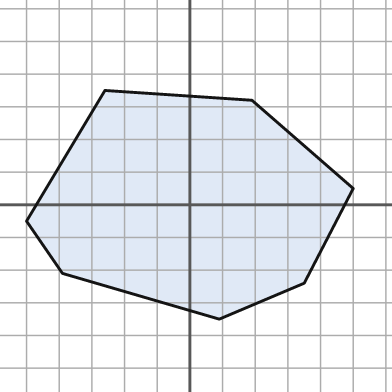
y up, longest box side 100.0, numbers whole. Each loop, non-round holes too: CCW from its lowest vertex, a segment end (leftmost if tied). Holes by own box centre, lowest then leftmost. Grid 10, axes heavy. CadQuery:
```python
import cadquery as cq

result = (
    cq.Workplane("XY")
    .moveTo(9.0, -35.0)
    .lineTo(35.0, -24.0)
    .lineTo(50.0, 5.0)
    .lineTo(19.0, 32.0)
    .lineTo(-26.0, 35.0)
    .lineTo(-50.0, -5.0)
    .lineTo(-39.0, -21.0)
    .close()
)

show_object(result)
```